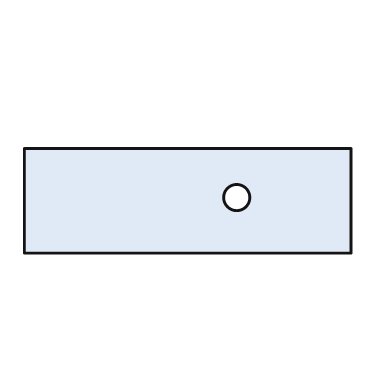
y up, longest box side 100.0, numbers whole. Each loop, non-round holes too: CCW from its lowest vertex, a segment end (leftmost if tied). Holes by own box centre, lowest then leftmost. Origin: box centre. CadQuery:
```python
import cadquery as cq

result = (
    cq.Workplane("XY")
    .moveTo(-50.0, -16.0)
    .lineTo(50.0, -16.0)
    .lineTo(50.0, 16.0)
    .lineTo(-50.0, 16.0)
    .close()
    .moveTo(15.0, 1.0)
    .circle(4.0)
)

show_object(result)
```